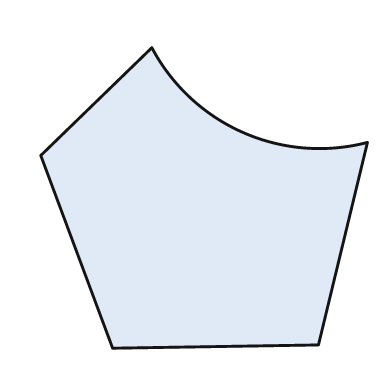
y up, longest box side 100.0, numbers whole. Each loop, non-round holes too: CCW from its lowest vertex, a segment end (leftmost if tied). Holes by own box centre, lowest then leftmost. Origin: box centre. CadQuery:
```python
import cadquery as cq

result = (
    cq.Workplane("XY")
    .moveTo(-28.0, -46.0)
    .lineTo(35.0, -45.0)
    .lineTo(50.0, 17.0)
    .threePointArc((12.0, 20.0), (-16.0, 46.0))
    .lineTo(-50.0, 13.0)
    .close()
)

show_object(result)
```